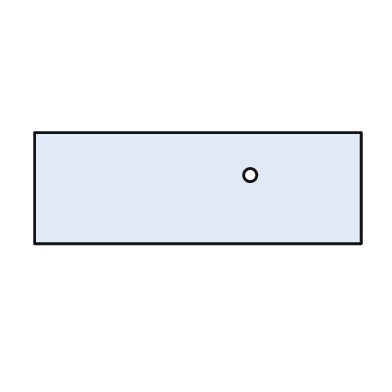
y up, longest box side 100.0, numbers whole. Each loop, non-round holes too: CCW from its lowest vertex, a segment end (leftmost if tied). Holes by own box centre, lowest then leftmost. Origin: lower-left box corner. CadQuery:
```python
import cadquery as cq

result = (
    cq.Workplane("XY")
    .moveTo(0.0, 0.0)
    .lineTo(100.0, 0.0)
    .lineTo(100.0, 34.0)
    .lineTo(0.0, 34.0)
    .close()
    .moveTo(66.0, 21.0)
    .circle(2.0)
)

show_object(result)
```